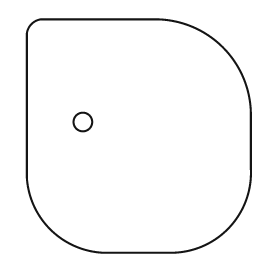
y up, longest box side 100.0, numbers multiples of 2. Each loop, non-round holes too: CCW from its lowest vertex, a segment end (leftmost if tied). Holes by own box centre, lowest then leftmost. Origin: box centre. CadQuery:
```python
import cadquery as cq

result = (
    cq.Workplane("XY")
    .moveTo(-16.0, -50.0)
    .lineTo(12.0, -50.0)
    .threePointArc((38.0, -40.0), (48.0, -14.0))
    .lineTo(48.0, 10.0)
    .threePointArc((36.0, 38.0), (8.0, 50.0))
    .lineTo(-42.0, 50.0)
    .threePointArc((-46.0, 48.0), (-48.0, 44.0))
    .lineTo(-48.0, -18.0)
    .threePointArc((-38.0, -40.0), (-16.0, -50.0))
    .close()
    .moveTo(-24.0, 6.0)
    .circle(4.0)
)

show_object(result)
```